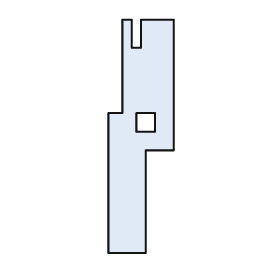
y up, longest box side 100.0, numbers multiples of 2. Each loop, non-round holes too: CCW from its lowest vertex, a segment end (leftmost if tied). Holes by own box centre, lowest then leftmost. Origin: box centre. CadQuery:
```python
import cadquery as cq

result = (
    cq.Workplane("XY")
    .moveTo(-14.0, -50.0)
    .lineTo(2.0, -50.0)
    .lineTo(2.0, -6.0)
    .lineTo(14.0, -6.0)
    .lineTo(14.0, 50.0)
    .lineTo(0.0, 50.0)
    .lineTo(0.0, 38.0)
    .lineTo(-4.0, 38.0)
    .lineTo(-4.0, 50.0)
    .lineTo(-8.0, 50.0)
    .lineTo(-8.0, 10.0)
    .lineTo(-14.0, 10.0)
    .close()
    .moveTo(-2.0, 2.0)
    .lineTo(6.0, 2.0)
    .lineTo(6.0, 10.0)
    .lineTo(-2.0, 10.0)
    .close()
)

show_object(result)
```